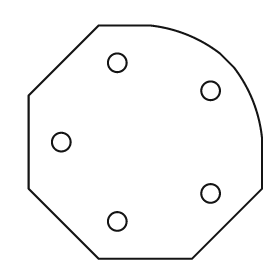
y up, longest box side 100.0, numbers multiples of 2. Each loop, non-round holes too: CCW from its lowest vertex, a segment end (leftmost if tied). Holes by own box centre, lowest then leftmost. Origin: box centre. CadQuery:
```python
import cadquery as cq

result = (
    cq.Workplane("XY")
    .moveTo(-20.0, -50.0)
    .lineTo(20.0, -50.0)
    .lineTo(50.0, -20.0)
    .lineTo(50.0, 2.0)
    .threePointArc((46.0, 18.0), (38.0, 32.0))
    .lineTo(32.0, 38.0)
    .threePointArc((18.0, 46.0), (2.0, 50.0))
    .lineTo(-20.0, 50.0)
    .lineTo(-50.0, 20.0)
    .lineTo(-50.0, -20.0)
    .close()
    .moveTo(-12.0, -34.0)
    .circle(4.0)
    .moveTo(28.0, -22.0)
    .circle(4.0)
    .moveTo(-36.0, 0.0)
    .circle(4.0)
    .moveTo(28.0, 22.0)
    .circle(4.0)
    .moveTo(-12.0, 34.0)
    .circle(4.0)
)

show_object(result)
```